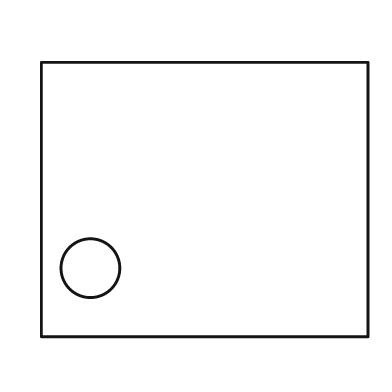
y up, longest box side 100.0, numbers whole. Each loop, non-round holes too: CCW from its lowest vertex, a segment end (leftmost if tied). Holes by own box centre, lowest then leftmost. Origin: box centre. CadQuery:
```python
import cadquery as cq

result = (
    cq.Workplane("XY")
    .moveTo(-50.0, -42.0)
    .lineTo(50.0, -42.0)
    .lineTo(50.0, 42.0)
    .lineTo(-50.0, 42.0)
    .close()
    .moveTo(-35.0, -21.0)
    .circle(9.0)
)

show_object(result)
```